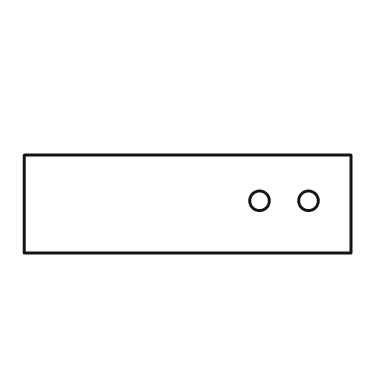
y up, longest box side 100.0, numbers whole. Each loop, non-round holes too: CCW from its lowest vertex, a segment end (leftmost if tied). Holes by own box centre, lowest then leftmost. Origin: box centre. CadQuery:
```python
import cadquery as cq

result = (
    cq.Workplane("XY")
    .moveTo(-50.0, -15.0)
    .lineTo(50.0, -15.0)
    .lineTo(50.0, 15.0)
    .lineTo(-50.0, 15.0)
    .close()
    .moveTo(22.0, 1.0)
    .circle(3.0)
    .moveTo(37.0, 1.0)
    .circle(3.0)
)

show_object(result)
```